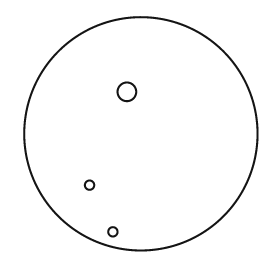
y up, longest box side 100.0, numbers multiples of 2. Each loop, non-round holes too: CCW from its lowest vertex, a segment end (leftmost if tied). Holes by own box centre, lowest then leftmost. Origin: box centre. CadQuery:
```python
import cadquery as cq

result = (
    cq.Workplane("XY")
    .moveTo(0.0, 0.0)
    .circle(50.0)
    .moveTo(-12.0, -42.0)
    .circle(2.0)
    .moveTo(-22.0, -22.0)
    .circle(2.0)
    .moveTo(-6.0, 18.0)
    .circle(4.0)
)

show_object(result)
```